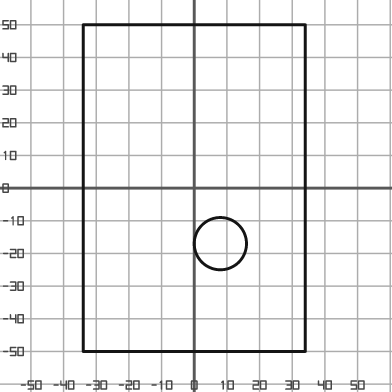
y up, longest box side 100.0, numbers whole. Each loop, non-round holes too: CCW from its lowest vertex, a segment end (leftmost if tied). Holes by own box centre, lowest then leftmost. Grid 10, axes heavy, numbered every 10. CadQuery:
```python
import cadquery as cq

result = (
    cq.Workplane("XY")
    .moveTo(-34.0, -50.0)
    .lineTo(34.0, -50.0)
    .lineTo(34.0, 50.0)
    .lineTo(-34.0, 50.0)
    .close()
    .moveTo(8.0, -17.0)
    .circle(8.0)
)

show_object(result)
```